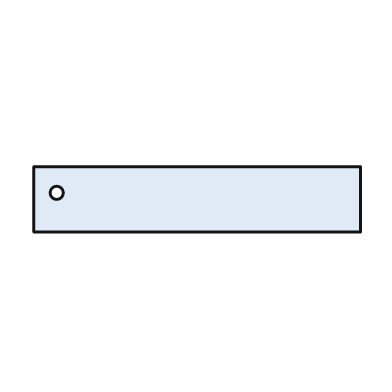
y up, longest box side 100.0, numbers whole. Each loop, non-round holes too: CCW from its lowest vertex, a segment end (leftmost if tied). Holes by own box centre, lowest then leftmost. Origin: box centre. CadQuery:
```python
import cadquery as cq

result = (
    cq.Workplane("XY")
    .moveTo(-50.0, -10.0)
    .lineTo(50.0, -10.0)
    .lineTo(50.0, 10.0)
    .lineTo(-50.0, 10.0)
    .close()
    .moveTo(-43.0, 2.0)
    .circle(2.0)
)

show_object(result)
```